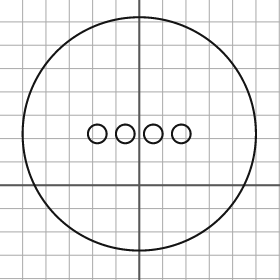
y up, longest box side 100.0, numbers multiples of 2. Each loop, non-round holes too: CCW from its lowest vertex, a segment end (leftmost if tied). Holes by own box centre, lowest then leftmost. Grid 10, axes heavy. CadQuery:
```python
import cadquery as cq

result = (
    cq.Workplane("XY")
    .moveTo(0.0, 22.0)
    .circle(50.0)
    .moveTo(-18.0, 22.0)
    .circle(4.0)
    .moveTo(-6.0, 22.0)
    .circle(4.0)
    .moveTo(6.0, 22.0)
    .circle(4.0)
    .moveTo(18.0, 22.0)
    .circle(4.0)
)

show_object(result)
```